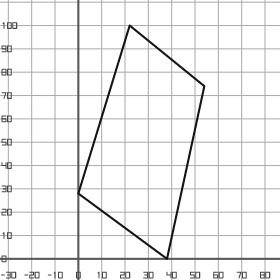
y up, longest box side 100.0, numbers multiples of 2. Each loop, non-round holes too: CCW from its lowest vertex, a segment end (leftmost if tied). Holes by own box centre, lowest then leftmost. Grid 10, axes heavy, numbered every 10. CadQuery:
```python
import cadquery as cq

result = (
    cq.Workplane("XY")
    .moveTo(38.0, 0.0)
    .lineTo(54.0, 74.0)
    .lineTo(22.0, 100.0)
    .lineTo(0.0, 28.0)
    .close()
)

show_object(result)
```